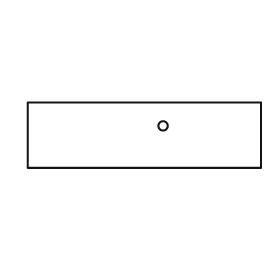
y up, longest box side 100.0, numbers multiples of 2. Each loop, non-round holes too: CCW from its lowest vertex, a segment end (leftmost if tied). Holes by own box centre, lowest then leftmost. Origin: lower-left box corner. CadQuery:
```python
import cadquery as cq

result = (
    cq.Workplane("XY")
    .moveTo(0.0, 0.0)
    .lineTo(100.0, 0.0)
    .lineTo(100.0, 28.0)
    .lineTo(0.0, 28.0)
    .close()
    .moveTo(58.0, 18.0)
    .circle(2.0)
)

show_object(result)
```